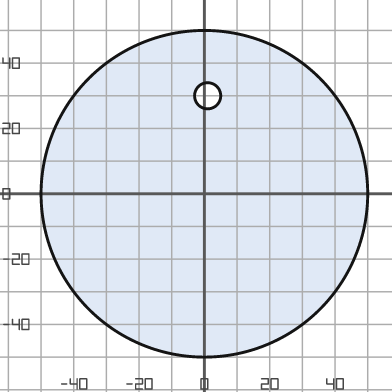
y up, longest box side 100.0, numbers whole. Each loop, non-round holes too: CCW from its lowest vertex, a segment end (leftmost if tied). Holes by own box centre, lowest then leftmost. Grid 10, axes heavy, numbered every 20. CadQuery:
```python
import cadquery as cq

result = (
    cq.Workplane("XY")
    .moveTo(0.0, 0.0)
    .circle(50.0)
    .moveTo(1.0, 30.0)
    .circle(4.0)
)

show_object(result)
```